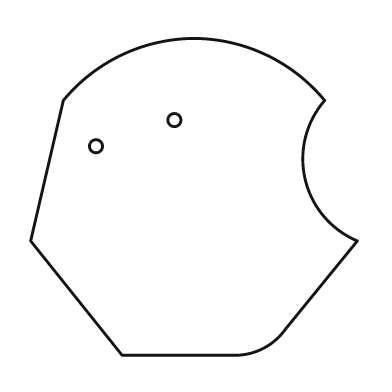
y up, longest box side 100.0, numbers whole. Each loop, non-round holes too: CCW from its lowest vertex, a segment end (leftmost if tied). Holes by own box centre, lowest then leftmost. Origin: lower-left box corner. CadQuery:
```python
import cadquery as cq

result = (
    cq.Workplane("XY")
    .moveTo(28.0, 0.0)
    .lineTo(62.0, 0.0)
    .threePointArc((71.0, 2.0), (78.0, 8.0))
    .lineTo(100.0, 35.0)
    .threePointArc((84.0, 54.0), (90.0, 78.0))
    .threePointArc((72.0, 92.0), (50.0, 97.0))
    .threePointArc((28.0, 92.0), (10.0, 78.0))
    .lineTo(0.0, 35.0)
    .close()
    .moveTo(20.0, 64.0)
    .circle(2.0)
    .moveTo(44.0, 72.0)
    .circle(2.0)
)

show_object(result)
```